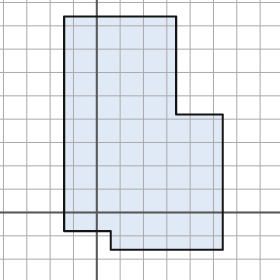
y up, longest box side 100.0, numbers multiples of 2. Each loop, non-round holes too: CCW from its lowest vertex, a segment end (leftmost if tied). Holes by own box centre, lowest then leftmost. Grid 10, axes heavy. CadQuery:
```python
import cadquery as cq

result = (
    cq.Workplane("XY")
    .moveTo(6.0, -16.0)
    .lineTo(54.0, -16.0)
    .lineTo(54.0, 42.0)
    .lineTo(34.0, 42.0)
    .lineTo(34.0, 84.0)
    .lineTo(-14.0, 84.0)
    .lineTo(-14.0, -8.0)
    .lineTo(6.0, -8.0)
    .close()
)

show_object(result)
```